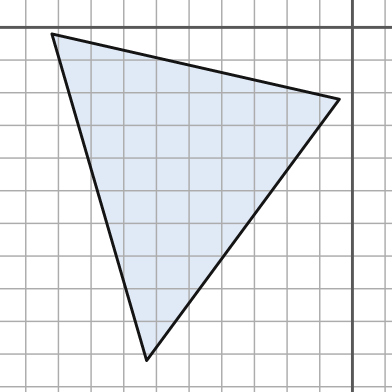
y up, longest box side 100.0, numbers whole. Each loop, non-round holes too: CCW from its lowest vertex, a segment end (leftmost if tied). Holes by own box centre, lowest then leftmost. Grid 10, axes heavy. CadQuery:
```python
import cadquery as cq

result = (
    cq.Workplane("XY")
    .moveTo(-63.0, -102.0)
    .lineTo(-4.0, -22.0)
    .lineTo(-92.0, -2.0)
    .close()
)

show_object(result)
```